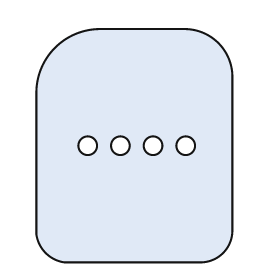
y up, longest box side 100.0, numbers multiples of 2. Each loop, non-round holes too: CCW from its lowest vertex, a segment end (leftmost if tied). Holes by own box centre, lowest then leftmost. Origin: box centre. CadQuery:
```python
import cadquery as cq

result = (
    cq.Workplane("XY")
    .moveTo(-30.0, -50.0)
    .lineTo(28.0, -50.0)
    .threePointArc((38.0, -46.0), (42.0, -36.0))
    .lineTo(42.0, 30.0)
    .threePointArc((36.0, 44.0), (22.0, 50.0))
    .lineTo(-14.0, 50.0)
    .threePointArc((-34.0, 42.0), (-42.0, 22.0))
    .lineTo(-42.0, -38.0)
    .threePointArc((-38.0, -46.0), (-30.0, -50.0))
    .close()
    .moveTo(-20.0, 0.0)
    .circle(4.0)
    .moveTo(-6.0, 0.0)
    .circle(4.0)
    .moveTo(8.0, 0.0)
    .circle(4.0)
    .moveTo(22.0, 0.0)
    .circle(4.0)
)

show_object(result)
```